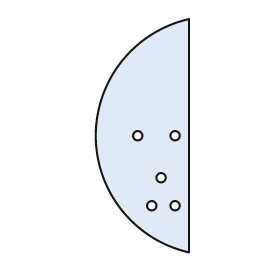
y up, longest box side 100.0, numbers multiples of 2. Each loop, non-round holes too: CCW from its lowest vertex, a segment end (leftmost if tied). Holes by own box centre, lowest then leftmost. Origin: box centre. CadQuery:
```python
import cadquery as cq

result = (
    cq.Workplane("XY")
    .moveTo(20.0, -50.0)
    .lineTo(20.0, 50.0)
    .threePointArc((-20.0, 0.0), (20.0, -50.0))
    .close()
    .moveTo(4.0, -30.0)
    .circle(2.0)
    .moveTo(14.0, -30.0)
    .circle(2.0)
    .moveTo(8.0, -18.0)
    .circle(2.0)
    .moveTo(-2.0, 0.0)
    .circle(2.0)
    .moveTo(14.0, 0.0)
    .circle(2.0)
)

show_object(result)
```